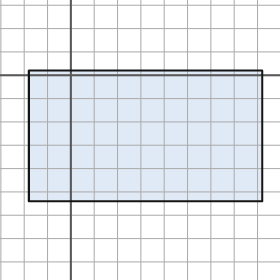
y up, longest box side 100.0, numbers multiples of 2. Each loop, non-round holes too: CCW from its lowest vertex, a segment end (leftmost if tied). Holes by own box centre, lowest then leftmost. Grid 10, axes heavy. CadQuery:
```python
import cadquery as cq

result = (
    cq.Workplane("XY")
    .moveTo(-18.0, -54.0)
    .lineTo(82.0, -54.0)
    .lineTo(82.0, 2.0)
    .lineTo(-18.0, 2.0)
    .close()
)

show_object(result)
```